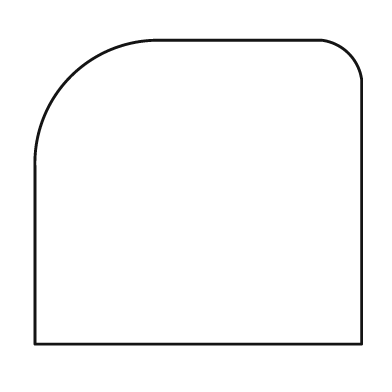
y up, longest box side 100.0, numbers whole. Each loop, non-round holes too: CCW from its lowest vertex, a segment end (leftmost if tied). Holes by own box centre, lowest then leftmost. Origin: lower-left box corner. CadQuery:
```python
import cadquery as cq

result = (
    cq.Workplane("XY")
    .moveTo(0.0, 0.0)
    .lineTo(100.0, 0.0)
    .lineTo(100.0, 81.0)
    .threePointArc((96.0, 89.0), (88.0, 93.0))
    .lineTo(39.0, 93.0)
    .threePointArc((11.0, 82.0), (0.0, 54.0))
    .close()
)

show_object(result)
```